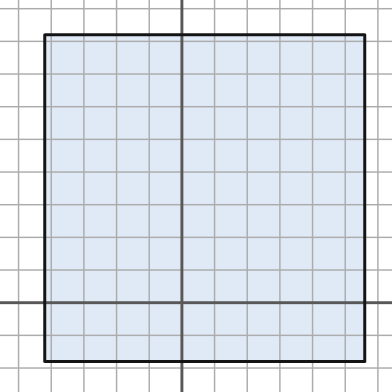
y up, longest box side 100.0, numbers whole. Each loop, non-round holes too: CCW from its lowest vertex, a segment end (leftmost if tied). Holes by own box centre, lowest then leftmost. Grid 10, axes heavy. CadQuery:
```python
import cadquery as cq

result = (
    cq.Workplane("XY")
    .moveTo(-42.0, -18.0)
    .lineTo(56.0, -18.0)
    .lineTo(56.0, 82.0)
    .lineTo(-42.0, 82.0)
    .close()
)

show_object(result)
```